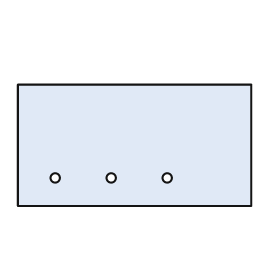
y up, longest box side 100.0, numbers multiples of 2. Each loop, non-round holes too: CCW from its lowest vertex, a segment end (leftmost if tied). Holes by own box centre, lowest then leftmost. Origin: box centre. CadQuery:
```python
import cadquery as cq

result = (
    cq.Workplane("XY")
    .moveTo(-50.0, -26.0)
    .lineTo(50.0, -26.0)
    .lineTo(50.0, 26.0)
    .lineTo(-50.0, 26.0)
    .close()
    .moveTo(-34.0, -14.0)
    .circle(2.0)
    .moveTo(-10.0, -14.0)
    .circle(2.0)
    .moveTo(14.0, -14.0)
    .circle(2.0)
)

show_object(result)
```